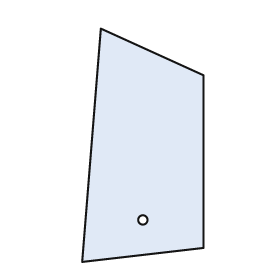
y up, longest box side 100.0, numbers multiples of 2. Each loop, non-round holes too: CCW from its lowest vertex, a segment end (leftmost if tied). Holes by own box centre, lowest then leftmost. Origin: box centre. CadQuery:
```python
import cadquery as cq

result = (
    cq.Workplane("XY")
    .moveTo(-26.0, -50.0)
    .lineTo(26.0, -44.0)
    .lineTo(26.0, 30.0)
    .lineTo(-18.0, 50.0)
    .close()
    .moveTo(0.0, -32.0)
    .circle(2.0)
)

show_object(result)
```